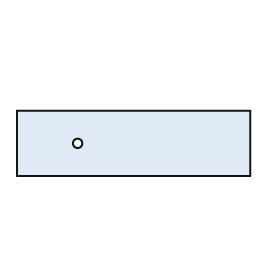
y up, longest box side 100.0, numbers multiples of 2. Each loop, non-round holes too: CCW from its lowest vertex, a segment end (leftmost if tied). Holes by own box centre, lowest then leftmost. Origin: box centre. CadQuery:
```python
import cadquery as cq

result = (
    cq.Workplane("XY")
    .moveTo(-50.0, -14.0)
    .lineTo(50.0, -14.0)
    .lineTo(50.0, 14.0)
    .lineTo(-50.0, 14.0)
    .close()
    .moveTo(-24.0, 0.0)
    .circle(2.0)
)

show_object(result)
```